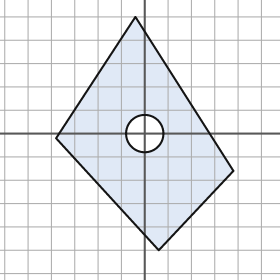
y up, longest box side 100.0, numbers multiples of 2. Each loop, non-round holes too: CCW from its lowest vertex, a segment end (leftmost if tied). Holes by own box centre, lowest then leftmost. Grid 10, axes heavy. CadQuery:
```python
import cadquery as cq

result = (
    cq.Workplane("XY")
    .moveTo(6.0, -50.0)
    .lineTo(38.0, -16.0)
    .lineTo(-4.0, 50.0)
    .lineTo(-38.0, -2.0)
    .close()
    .moveTo(0.0, 0.0)
    .circle(8.0)
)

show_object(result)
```